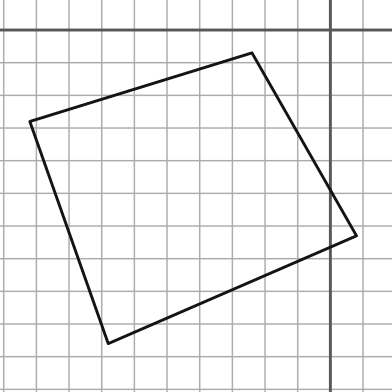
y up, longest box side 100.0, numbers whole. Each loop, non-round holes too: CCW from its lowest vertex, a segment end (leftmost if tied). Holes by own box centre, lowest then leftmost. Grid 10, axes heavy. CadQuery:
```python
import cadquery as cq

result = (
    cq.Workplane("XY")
    .moveTo(-68.0, -96.0)
    .lineTo(8.0, -63.0)
    .lineTo(-24.0, -7.0)
    .lineTo(-92.0, -28.0)
    .close()
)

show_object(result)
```